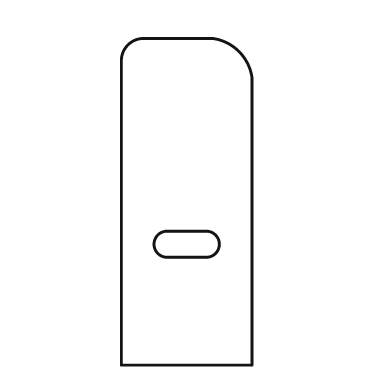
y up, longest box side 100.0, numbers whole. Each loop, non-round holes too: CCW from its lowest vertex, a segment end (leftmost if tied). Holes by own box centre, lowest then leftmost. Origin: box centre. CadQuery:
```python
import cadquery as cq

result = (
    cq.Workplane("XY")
    .moveTo(-20.0, -50.0)
    .lineTo(20.0, -50.0)
    .lineTo(20.0, 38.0)
    .threePointArc((16.0, 46.0), (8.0, 50.0))
    .lineTo(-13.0, 50.0)
    .threePointArc((-18.0, 48.0), (-20.0, 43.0))
    .close()
    .moveTo(-6.0, -17.0)
    .lineTo(6.0, -17.0)
    .threePointArc((10.0, -13.0), (6.0, -9.0))
    .lineTo(-6.0, -9.0)
    .threePointArc((-10.0, -13.0), (-6.0, -17.0))
    .close()
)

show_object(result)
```